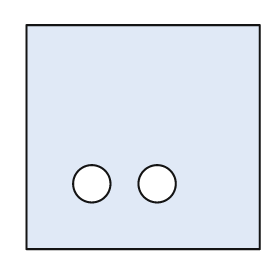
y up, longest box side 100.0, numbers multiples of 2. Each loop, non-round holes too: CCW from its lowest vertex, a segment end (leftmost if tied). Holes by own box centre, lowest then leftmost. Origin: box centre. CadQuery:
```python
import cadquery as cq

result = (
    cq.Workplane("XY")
    .moveTo(-50.0, -48.0)
    .lineTo(50.0, -48.0)
    .lineTo(50.0, 48.0)
    .lineTo(-50.0, 48.0)
    .close()
    .moveTo(-22.0, -20.0)
    .circle(8.0)
    .moveTo(6.0, -20.0)
    .circle(8.0)
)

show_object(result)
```